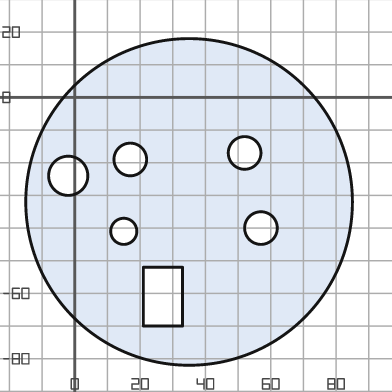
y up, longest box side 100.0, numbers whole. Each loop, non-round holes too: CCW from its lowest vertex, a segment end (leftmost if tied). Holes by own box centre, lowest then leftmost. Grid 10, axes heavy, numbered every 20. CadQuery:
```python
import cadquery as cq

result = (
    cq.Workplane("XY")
    .moveTo(35.0, -32.0)
    .circle(50.0)
    .moveTo(21.0, -70.0)
    .lineTo(33.0, -70.0)
    .lineTo(33.0, -52.0)
    .lineTo(21.0, -52.0)
    .close()
    .moveTo(15.0, -41.0)
    .circle(4.0)
    .moveTo(57.0, -40.0)
    .circle(5.0)
    .moveTo(-2.0, -24.0)
    .circle(6.0)
    .moveTo(17.0, -19.0)
    .circle(5.0)
    .moveTo(52.0, -17.0)
    .circle(5.0)
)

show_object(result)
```